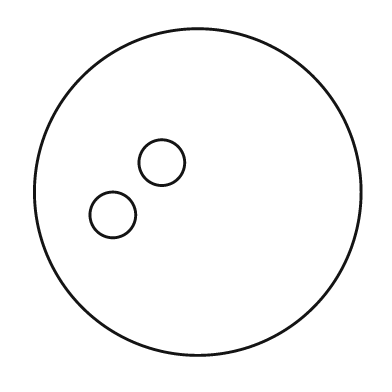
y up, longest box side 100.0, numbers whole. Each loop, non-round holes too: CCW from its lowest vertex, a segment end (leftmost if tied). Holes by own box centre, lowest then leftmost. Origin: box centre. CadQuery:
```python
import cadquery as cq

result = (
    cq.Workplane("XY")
    .moveTo(0.0, 0.0)
    .circle(50.0)
    .moveTo(-26.0, -7.0)
    .circle(7.0)
    .moveTo(-11.0, 9.0)
    .circle(7.0)
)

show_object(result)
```